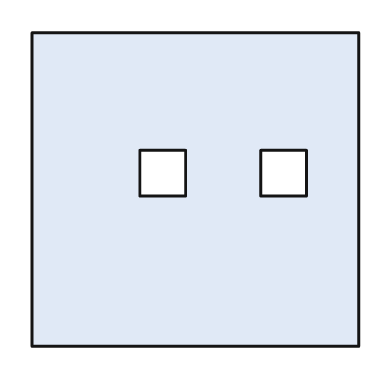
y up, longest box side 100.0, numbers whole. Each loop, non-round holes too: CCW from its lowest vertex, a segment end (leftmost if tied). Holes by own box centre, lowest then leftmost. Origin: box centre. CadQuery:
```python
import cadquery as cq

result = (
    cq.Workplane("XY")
    .moveTo(-50.0, -48.0)
    .lineTo(50.0, -48.0)
    .lineTo(50.0, 48.0)
    .lineTo(-50.0, 48.0)
    .close()
    .moveTo(-17.0, -2.0)
    .lineTo(-3.0, -2.0)
    .lineTo(-3.0, 12.0)
    .lineTo(-17.0, 12.0)
    .close()
    .moveTo(20.0, -2.0)
    .lineTo(34.0, -2.0)
    .lineTo(34.0, 12.0)
    .lineTo(20.0, 12.0)
    .close()
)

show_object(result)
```